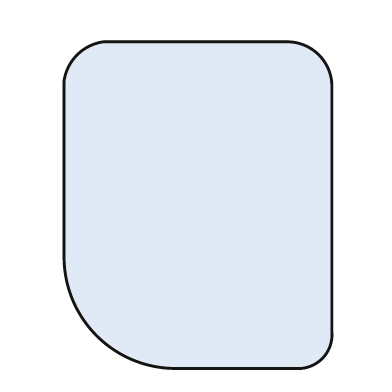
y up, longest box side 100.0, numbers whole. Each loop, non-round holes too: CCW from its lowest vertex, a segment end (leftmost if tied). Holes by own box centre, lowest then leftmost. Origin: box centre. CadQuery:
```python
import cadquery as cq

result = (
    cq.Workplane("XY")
    .moveTo(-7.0, -50.0)
    .lineTo(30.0, -50.0)
    .threePointArc((38.0, -47.0), (41.0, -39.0))
    .lineTo(41.0, 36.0)
    .threePointArc((37.0, 46.0), (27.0, 50.0))
    .lineTo(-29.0, 50.0)
    .threePointArc((-37.0, 46.0), (-41.0, 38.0))
    .lineTo(-41.0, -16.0)
    .threePointArc((-31.0, -40.0), (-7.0, -50.0))
    .close()
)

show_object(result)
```